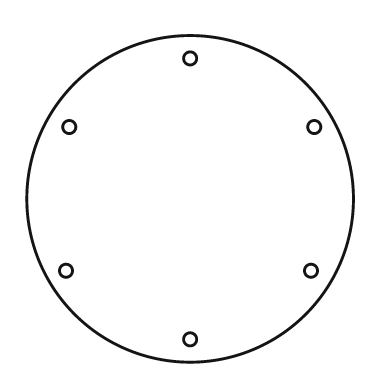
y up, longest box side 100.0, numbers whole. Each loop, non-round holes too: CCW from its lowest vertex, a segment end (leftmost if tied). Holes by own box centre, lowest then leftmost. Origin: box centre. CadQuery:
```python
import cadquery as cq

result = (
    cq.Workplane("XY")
    .moveTo(0.0, 0.0)
    .circle(50.0)
    .moveTo(0.0, -43.0)
    .circle(2.0)
    .moveTo(-38.0, -22.0)
    .circle(2.0)
    .moveTo(37.0, -22.0)
    .circle(2.0)
    .moveTo(-37.0, 22.0)
    .circle(2.0)
    .moveTo(38.0, 22.0)
    .circle(2.0)
    .moveTo(0.0, 43.0)
    .circle(2.0)
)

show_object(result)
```